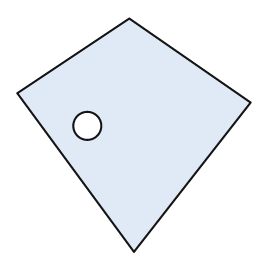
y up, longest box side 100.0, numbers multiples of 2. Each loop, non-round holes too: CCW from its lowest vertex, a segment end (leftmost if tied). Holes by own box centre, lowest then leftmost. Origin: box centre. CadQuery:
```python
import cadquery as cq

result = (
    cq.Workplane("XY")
    .moveTo(0.0, -50.0)
    .lineTo(50.0, 14.0)
    .lineTo(-2.0, 50.0)
    .lineTo(-50.0, 18.0)
    .close()
    .moveTo(-20.0, 4.0)
    .circle(6.0)
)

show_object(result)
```